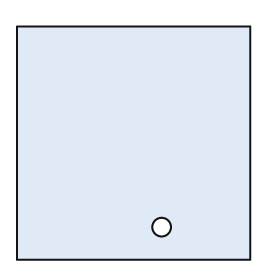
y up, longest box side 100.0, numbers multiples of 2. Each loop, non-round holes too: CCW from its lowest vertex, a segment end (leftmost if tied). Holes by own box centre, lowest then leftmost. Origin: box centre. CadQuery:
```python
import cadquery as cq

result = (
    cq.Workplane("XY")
    .moveTo(-50.0, -50.0)
    .lineTo(50.0, -50.0)
    .lineTo(50.0, 50.0)
    .lineTo(-50.0, 50.0)
    .close()
    .moveTo(12.0, -36.0)
    .circle(4.0)
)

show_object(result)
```